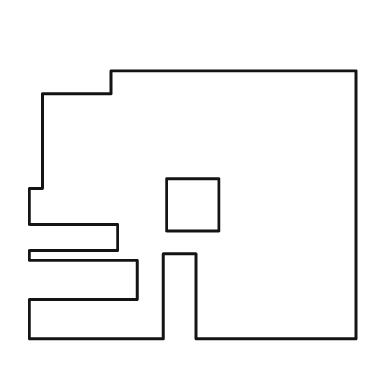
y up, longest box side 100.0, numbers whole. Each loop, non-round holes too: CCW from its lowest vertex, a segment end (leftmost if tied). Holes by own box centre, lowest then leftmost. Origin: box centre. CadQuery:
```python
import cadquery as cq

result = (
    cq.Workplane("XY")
    .moveTo(-50.0, -41.0)
    .lineTo(-9.0, -41.0)
    .lineTo(-9.0, -15.0)
    .lineTo(1.0, -15.0)
    .lineTo(1.0, -41.0)
    .lineTo(50.0, -41.0)
    .lineTo(50.0, 41.0)
    .lineTo(-25.0, 41.0)
    .lineTo(-25.0, 34.0)
    .lineTo(-46.0, 34.0)
    .lineTo(-46.0, 5.0)
    .lineTo(-50.0, 5.0)
    .lineTo(-50.0, -6.0)
    .lineTo(-23.0, -6.0)
    .lineTo(-23.0, -14.0)
    .lineTo(-50.0, -14.0)
    .lineTo(-50.0, -17.0)
    .lineTo(-17.0, -17.0)
    .lineTo(-17.0, -29.0)
    .lineTo(-50.0, -29.0)
    .close()
    .moveTo(-8.0, -8.0)
    .lineTo(8.0, -8.0)
    .lineTo(8.0, 8.0)
    .lineTo(-8.0, 8.0)
    .close()
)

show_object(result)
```